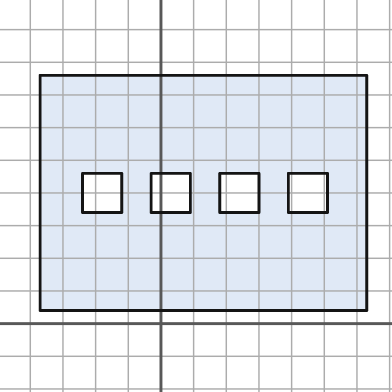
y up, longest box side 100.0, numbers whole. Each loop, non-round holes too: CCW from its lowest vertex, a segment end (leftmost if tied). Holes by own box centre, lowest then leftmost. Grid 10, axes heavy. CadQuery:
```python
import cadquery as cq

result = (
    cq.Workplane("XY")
    .moveTo(-37.0, 4.0)
    .lineTo(63.0, 4.0)
    .lineTo(63.0, 76.0)
    .lineTo(-37.0, 76.0)
    .close()
    .moveTo(-24.0, 34.0)
    .lineTo(-12.0, 34.0)
    .lineTo(-12.0, 46.0)
    .lineTo(-24.0, 46.0)
    .close()
    .moveTo(-3.0, 34.0)
    .lineTo(9.0, 34.0)
    .lineTo(9.0, 46.0)
    .lineTo(-3.0, 46.0)
    .close()
    .moveTo(18.0, 34.0)
    .lineTo(30.0, 34.0)
    .lineTo(30.0, 46.0)
    .lineTo(18.0, 46.0)
    .close()
    .moveTo(39.0, 34.0)
    .lineTo(51.0, 34.0)
    .lineTo(51.0, 46.0)
    .lineTo(39.0, 46.0)
    .close()
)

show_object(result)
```